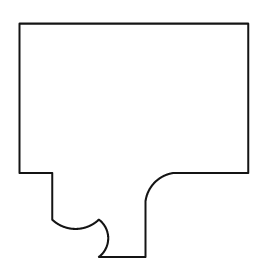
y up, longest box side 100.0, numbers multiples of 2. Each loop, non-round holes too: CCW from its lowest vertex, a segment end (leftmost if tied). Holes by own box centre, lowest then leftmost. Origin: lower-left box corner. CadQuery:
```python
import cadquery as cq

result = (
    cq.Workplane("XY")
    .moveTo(34.0, 0.0)
    .lineTo(54.0, 0.0)
    .lineTo(54.0, 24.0)
    .threePointArc((58.0, 32.0), (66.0, 36.0))
    .lineTo(98.0, 36.0)
    .lineTo(98.0, 100.0)
    .lineTo(0.0, 100.0)
    .lineTo(0.0, 36.0)
    .lineTo(14.0, 36.0)
    .lineTo(14.0, 16.0)
    .threePointArc((24.0, 12.0), (34.0, 16.0))
    .threePointArc((38.0, 8.0), (34.0, 0.0))
    .close()
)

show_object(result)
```